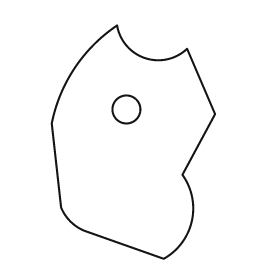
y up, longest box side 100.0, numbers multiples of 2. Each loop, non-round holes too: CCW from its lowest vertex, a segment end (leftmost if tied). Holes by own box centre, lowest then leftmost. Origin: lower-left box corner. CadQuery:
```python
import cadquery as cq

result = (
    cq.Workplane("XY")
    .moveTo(48.0, 0.0)
    .threePointArc((60.0, 16.0), (56.0, 36.0))
    .lineTo(70.0, 62.0)
    .lineTo(58.0, 90.0)
    .threePointArc((40.0, 86.0), (28.0, 100.0))
    .threePointArc((10.0, 82.0), (0.0, 58.0))
    .lineTo(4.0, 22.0)
    .threePointArc((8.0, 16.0), (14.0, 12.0))
    .close()
    .moveTo(32.0, 64.0)
    .circle(6.0)
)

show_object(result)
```